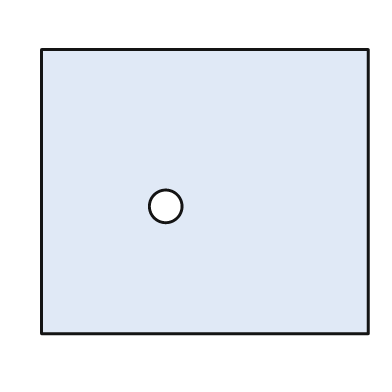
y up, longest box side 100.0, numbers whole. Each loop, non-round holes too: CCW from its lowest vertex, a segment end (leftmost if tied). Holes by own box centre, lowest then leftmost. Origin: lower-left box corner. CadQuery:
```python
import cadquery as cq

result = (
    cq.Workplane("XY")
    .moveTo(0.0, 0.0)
    .lineTo(100.0, 0.0)
    .lineTo(100.0, 87.0)
    .lineTo(0.0, 87.0)
    .close()
    .moveTo(38.0, 39.0)
    .circle(5.0)
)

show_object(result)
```